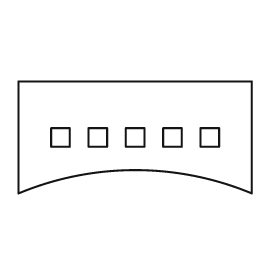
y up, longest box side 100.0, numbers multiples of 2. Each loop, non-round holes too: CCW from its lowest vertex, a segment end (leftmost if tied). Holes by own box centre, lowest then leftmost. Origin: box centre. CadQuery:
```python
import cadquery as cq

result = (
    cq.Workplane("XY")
    .moveTo(-50.0, -24.0)
    .threePointArc((0.0, -14.0), (50.0, -24.0))
    .lineTo(50.0, 24.0)
    .lineTo(-50.0, 24.0)
    .close()
    .moveTo(-36.0, -4.0)
    .lineTo(-28.0, -4.0)
    .lineTo(-28.0, 4.0)
    .lineTo(-36.0, 4.0)
    .close()
    .moveTo(-20.0, -4.0)
    .lineTo(-12.0, -4.0)
    .lineTo(-12.0, 4.0)
    .lineTo(-20.0, 4.0)
    .close()
    .moveTo(-4.0, -4.0)
    .lineTo(4.0, -4.0)
    .lineTo(4.0, 4.0)
    .lineTo(-4.0, 4.0)
    .close()
    .moveTo(12.0, -4.0)
    .lineTo(20.0, -4.0)
    .lineTo(20.0, 4.0)
    .lineTo(12.0, 4.0)
    .close()
    .moveTo(28.0, -4.0)
    .lineTo(36.0, -4.0)
    .lineTo(36.0, 4.0)
    .lineTo(28.0, 4.0)
    .close()
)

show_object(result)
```